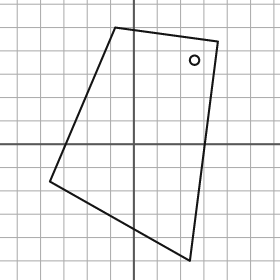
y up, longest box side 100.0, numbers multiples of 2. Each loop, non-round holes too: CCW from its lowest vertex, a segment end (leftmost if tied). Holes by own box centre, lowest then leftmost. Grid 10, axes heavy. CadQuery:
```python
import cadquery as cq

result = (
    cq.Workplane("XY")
    .moveTo(24.0, -50.0)
    .lineTo(36.0, 44.0)
    .lineTo(-8.0, 50.0)
    .lineTo(-36.0, -16.0)
    .close()
    .moveTo(26.0, 36.0)
    .circle(2.0)
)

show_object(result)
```